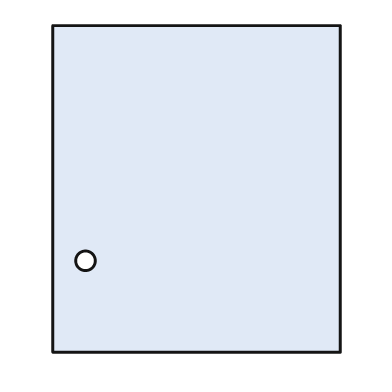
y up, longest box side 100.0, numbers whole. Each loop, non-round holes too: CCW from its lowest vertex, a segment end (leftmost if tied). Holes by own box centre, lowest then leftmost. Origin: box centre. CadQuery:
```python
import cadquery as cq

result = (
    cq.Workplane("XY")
    .moveTo(-44.0, -50.0)
    .lineTo(44.0, -50.0)
    .lineTo(44.0, 50.0)
    .lineTo(-44.0, 50.0)
    .close()
    .moveTo(-34.0, -22.0)
    .circle(3.0)
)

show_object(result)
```